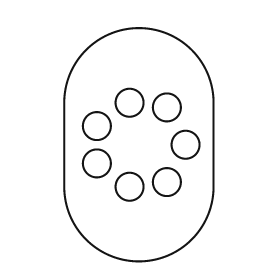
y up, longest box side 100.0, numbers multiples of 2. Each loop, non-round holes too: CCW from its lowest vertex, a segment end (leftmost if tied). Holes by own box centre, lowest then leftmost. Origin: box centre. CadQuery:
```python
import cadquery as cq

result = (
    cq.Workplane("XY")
    .moveTo(-32.0, -18.0)
    .threePointArc((0.0, -50.0), (32.0, -18.0))
    .lineTo(32.0, 18.0)
    .threePointArc((0.0, 50.0), (-32.0, 18.0))
    .close()
    .moveTo(-4.0, -18.0)
    .circle(6.0)
    .moveTo(12.0, -16.0)
    .circle(6.0)
    .moveTo(-18.0, -8.0)
    .circle(6.0)
    .moveTo(20.0, 0.0)
    .circle(6.0)
    .moveTo(-18.0, 8.0)
    .circle(6.0)
    .moveTo(12.0, 16.0)
    .circle(6.0)
    .moveTo(-4.0, 18.0)
    .circle(6.0)
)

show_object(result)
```